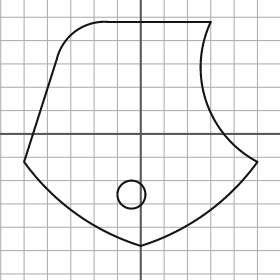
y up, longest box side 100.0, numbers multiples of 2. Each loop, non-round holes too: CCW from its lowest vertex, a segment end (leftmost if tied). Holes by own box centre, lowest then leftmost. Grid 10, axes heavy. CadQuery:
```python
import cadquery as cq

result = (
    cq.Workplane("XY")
    .moveTo(0.0, -48.0)
    .threePointArc((28.0, -34.0), (50.0, -12.0))
    .threePointArc((28.0, 14.0), (30.0, 48.0))
    .lineTo(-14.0, 48.0)
    .threePointArc((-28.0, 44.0), (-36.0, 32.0))
    .lineTo(-50.0, -12.0)
    .threePointArc((-28.0, -34.0), (0.0, -48.0))
    .close()
    .moveTo(-4.0, -26.0)
    .circle(6.0)
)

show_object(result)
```